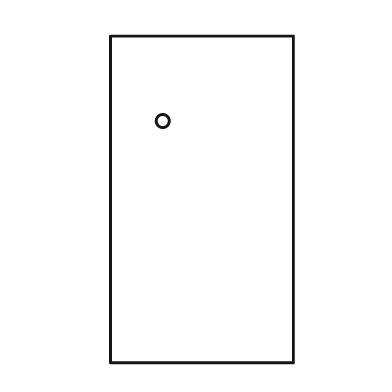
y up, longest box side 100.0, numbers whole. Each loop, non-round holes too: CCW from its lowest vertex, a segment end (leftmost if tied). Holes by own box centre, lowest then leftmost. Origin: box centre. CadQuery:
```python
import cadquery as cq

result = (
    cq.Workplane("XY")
    .moveTo(-28.0, -50.0)
    .lineTo(28.0, -50.0)
    .lineTo(28.0, 50.0)
    .lineTo(-28.0, 50.0)
    .close()
    .moveTo(-12.0, 24.0)
    .circle(2.0)
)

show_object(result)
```